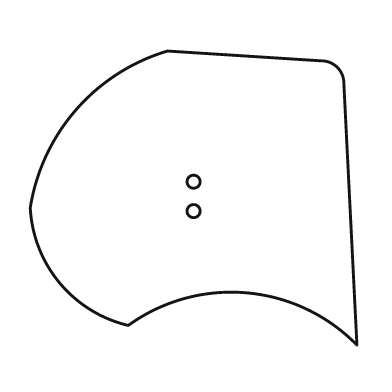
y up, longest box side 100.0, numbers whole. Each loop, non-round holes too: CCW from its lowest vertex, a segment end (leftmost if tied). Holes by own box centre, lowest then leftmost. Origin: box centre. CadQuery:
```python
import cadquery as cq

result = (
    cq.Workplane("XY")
    .moveTo(50.0, -45.0)
    .lineTo(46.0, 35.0)
    .threePointArc((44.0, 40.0), (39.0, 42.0))
    .lineTo(-8.0, 45.0)
    .threePointArc((-36.0, 27.0), (-50.0, -3.0))
    .threePointArc((-41.0, -26.0), (-20.0, -39.0))
    .threePointArc((16.0, -29.0), (50.0, -45.0))
    .close()
    .moveTo(0.0, -4.0)
    .circle(2.0)
    .moveTo(0.0, 5.0)
    .circle(2.0)
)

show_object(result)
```